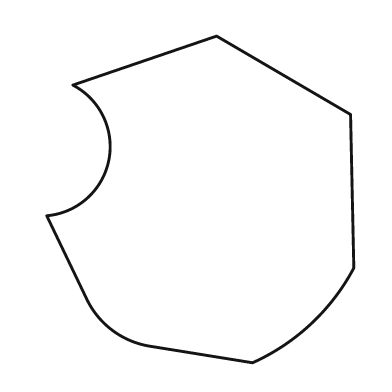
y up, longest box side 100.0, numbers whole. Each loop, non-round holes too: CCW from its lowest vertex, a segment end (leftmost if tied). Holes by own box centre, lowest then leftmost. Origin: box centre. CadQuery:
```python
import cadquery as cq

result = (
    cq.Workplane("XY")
    .moveTo(16.0, -50.0)
    .threePointArc((34.0, -38.0), (47.0, -21.0))
    .lineTo(46.0, 26.0)
    .lineTo(5.0, 50.0)
    .lineTo(-39.0, 35.0)
    .threePointArc((-28.0, 12.0), (-47.0, -5.0))
    .lineTo(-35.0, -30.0)
    .threePointArc((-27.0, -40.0), (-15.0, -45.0))
    .close()
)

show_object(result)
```